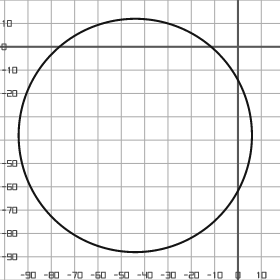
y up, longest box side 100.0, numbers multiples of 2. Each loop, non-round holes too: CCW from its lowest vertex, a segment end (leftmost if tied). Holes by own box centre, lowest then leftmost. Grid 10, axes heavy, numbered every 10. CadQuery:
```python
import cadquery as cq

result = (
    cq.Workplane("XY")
    .moveTo(-44.0, -38.0)
    .circle(50.0)
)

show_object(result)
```